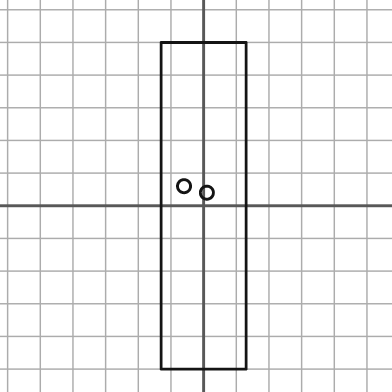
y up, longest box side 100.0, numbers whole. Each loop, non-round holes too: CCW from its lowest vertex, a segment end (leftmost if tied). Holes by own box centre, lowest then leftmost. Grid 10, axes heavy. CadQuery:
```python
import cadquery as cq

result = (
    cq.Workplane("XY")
    .moveTo(-13.0, -50.0)
    .lineTo(13.0, -50.0)
    .lineTo(13.0, 50.0)
    .lineTo(-13.0, 50.0)
    .close()
    .moveTo(1.0, 4.0)
    .circle(2.0)
    .moveTo(-6.0, 6.0)
    .circle(2.0)
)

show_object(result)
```